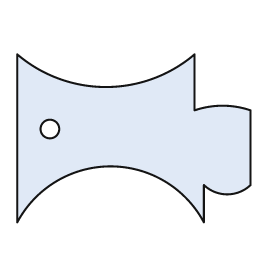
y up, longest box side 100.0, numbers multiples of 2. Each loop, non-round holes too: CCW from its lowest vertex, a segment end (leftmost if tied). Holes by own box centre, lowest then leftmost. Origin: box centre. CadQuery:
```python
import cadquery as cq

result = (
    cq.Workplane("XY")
    .moveTo(-50.0, -36.0)
    .threePointArc((-10.0, -12.0), (30.0, -36.0))
    .lineTo(30.0, -20.0)
    .threePointArc((40.0, -24.0), (50.0, -20.0))
    .lineTo(50.0, 12.0)
    .threePointArc((38.0, 14.0), (26.0, 12.0))
    .lineTo(26.0, 36.0)
    .threePointArc((-12.0, 22.0), (-50.0, 36.0))
    .close()
    .moveTo(-36.0, 4.0)
    .circle(4.0)
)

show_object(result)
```